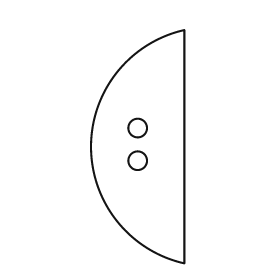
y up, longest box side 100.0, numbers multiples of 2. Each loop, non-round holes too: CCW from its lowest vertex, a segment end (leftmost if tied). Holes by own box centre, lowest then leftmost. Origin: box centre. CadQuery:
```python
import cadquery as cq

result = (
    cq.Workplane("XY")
    .moveTo(20.0, -50.0)
    .lineTo(20.0, 50.0)
    .threePointArc((-20.0, 0.0), (20.0, -50.0))
    .close()
    .moveTo(0.0, -6.0)
    .circle(4.0)
    .moveTo(0.0, 8.0)
    .circle(4.0)
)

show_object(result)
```